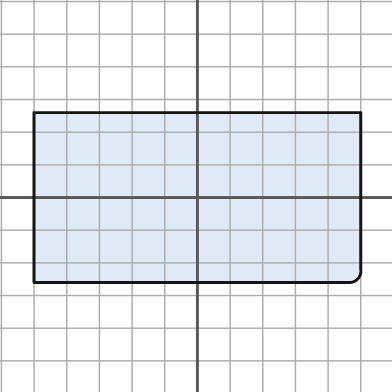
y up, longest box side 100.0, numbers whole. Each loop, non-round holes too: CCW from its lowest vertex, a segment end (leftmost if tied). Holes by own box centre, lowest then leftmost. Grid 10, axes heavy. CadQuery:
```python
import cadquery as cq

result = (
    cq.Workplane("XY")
    .moveTo(-50.0, -26.0)
    .lineTo(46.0, -26.0)
    .threePointArc((49.0, -25.0), (50.0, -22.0))
    .lineTo(50.0, 26.0)
    .lineTo(-50.0, 26.0)
    .close()
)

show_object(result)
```